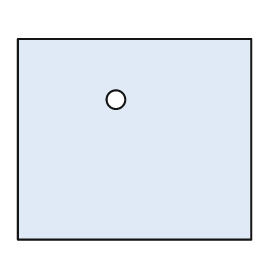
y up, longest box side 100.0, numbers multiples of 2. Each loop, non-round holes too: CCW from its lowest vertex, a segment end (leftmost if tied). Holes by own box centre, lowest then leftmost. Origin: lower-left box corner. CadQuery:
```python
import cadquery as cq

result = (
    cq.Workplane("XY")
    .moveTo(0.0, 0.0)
    .lineTo(100.0, 0.0)
    .lineTo(100.0, 86.0)
    .lineTo(0.0, 86.0)
    .close()
    .moveTo(42.0, 60.0)
    .circle(4.0)
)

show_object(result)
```